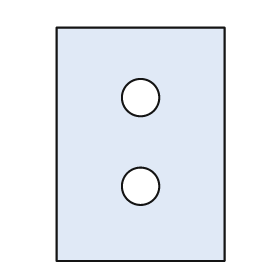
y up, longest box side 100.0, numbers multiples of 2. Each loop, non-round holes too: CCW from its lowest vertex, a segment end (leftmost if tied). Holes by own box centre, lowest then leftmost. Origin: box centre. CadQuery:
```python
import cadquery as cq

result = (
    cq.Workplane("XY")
    .moveTo(-36.0, -50.0)
    .lineTo(36.0, -50.0)
    .lineTo(36.0, 50.0)
    .lineTo(-36.0, 50.0)
    .close()
    .moveTo(0.0, -18.0)
    .circle(8.0)
    .moveTo(0.0, 20.0)
    .circle(8.0)
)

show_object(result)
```